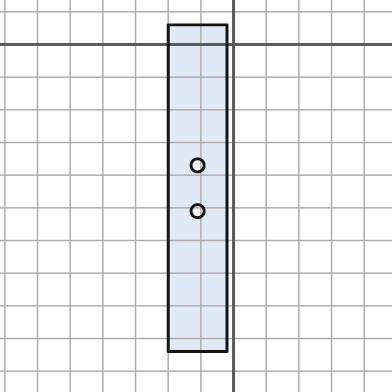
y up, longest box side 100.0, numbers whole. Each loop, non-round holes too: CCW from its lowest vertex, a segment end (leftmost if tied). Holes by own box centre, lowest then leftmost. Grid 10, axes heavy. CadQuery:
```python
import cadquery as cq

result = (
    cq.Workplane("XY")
    .moveTo(-20.0, -94.0)
    .lineTo(-2.0, -94.0)
    .lineTo(-2.0, 6.0)
    .lineTo(-20.0, 6.0)
    .close()
    .moveTo(-11.0, -51.0)
    .circle(2.0)
    .moveTo(-11.0, -37.0)
    .circle(2.0)
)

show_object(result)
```